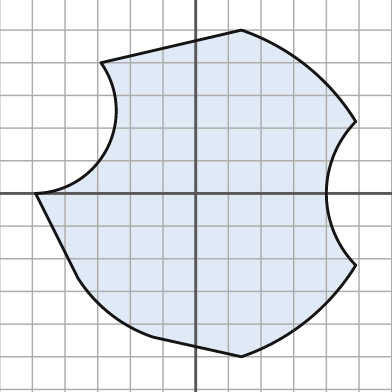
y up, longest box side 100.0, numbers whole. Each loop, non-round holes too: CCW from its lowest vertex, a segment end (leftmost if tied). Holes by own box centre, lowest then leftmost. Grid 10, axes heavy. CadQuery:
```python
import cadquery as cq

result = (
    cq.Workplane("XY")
    .moveTo(14.0, -50.0)
    .threePointArc((34.0, -39.0), (49.0, -22.0))
    .threePointArc((40.0, 0.0), (49.0, 22.0))
    .threePointArc((34.0, 39.0), (14.0, 50.0))
    .lineTo(-29.0, 40.0)
    .threePointArc((-27.0, 14.0), (-49.0, 0.0))
    .lineTo(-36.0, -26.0)
    .threePointArc((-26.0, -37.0), (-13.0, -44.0))
    .close()
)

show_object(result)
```